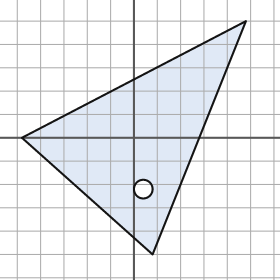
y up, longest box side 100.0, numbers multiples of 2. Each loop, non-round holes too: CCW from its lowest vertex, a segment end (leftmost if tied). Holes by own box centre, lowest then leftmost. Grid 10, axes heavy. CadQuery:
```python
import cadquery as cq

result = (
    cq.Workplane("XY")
    .moveTo(8.0, -50.0)
    .lineTo(48.0, 50.0)
    .lineTo(-48.0, 0.0)
    .close()
    .moveTo(4.0, -22.0)
    .circle(4.0)
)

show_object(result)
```